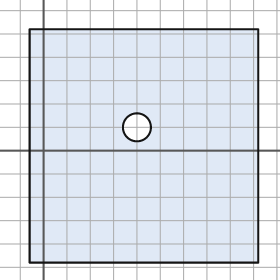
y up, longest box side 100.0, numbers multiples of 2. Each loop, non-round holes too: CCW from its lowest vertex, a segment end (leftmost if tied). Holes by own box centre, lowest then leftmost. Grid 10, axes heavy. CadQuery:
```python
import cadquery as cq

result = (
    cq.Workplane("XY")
    .moveTo(-6.0, -48.0)
    .lineTo(92.0, -48.0)
    .lineTo(92.0, 52.0)
    .lineTo(-6.0, 52.0)
    .close()
    .moveTo(40.0, 10.0)
    .circle(6.0)
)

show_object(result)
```